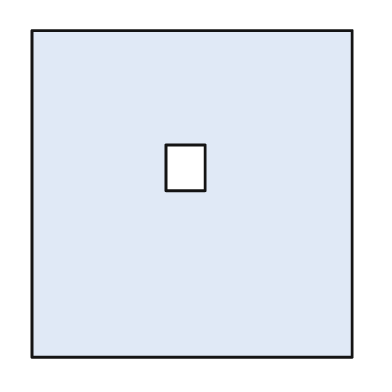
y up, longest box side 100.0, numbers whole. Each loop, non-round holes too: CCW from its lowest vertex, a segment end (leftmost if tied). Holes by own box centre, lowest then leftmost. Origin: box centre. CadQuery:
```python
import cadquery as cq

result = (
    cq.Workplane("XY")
    .moveTo(-49.0, -50.0)
    .lineTo(49.0, -50.0)
    .lineTo(49.0, 50.0)
    .lineTo(-49.0, 50.0)
    .close()
    .moveTo(-8.0, 1.0)
    .lineTo(4.0, 1.0)
    .lineTo(4.0, 15.0)
    .lineTo(-8.0, 15.0)
    .close()
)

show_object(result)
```